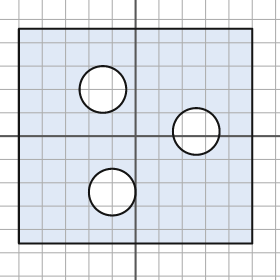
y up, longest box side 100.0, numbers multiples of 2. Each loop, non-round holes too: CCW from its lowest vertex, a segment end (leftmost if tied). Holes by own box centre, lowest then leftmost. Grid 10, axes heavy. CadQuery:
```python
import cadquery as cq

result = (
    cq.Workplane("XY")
    .moveTo(-50.0, -46.0)
    .lineTo(50.0, -46.0)
    .lineTo(50.0, 46.0)
    .lineTo(-50.0, 46.0)
    .close()
    .moveTo(-10.0, -24.0)
    .circle(10.0)
    .moveTo(26.0, 2.0)
    .circle(10.0)
    .moveTo(-14.0, 20.0)
    .circle(10.0)
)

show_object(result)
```